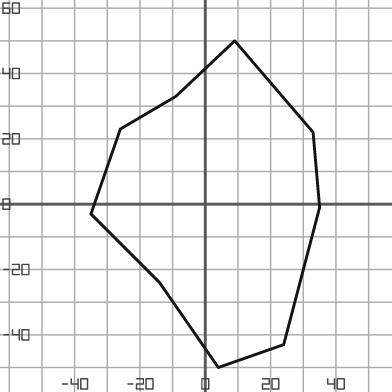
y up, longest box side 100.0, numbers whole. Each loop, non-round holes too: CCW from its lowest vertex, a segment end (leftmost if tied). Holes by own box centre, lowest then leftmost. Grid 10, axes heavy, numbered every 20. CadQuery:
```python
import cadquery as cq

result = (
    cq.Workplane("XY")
    .moveTo(4.0, -50.0)
    .lineTo(24.0, -43.0)
    .lineTo(35.0, -1.0)
    .lineTo(33.0, 22.0)
    .lineTo(9.0, 50.0)
    .lineTo(-9.0, 33.0)
    .lineTo(-26.0, 23.0)
    .lineTo(-35.0, -3.0)
    .lineTo(-14.0, -24.0)
    .close()
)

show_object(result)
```